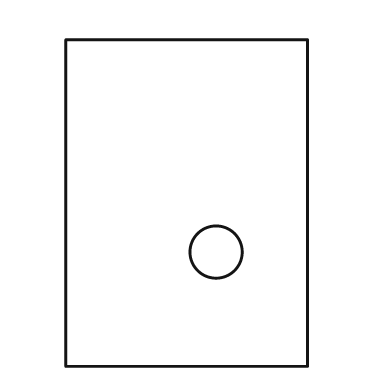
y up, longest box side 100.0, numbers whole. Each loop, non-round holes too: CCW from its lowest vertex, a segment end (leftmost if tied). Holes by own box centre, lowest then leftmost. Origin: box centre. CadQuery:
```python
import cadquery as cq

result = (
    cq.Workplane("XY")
    .moveTo(-37.0, -50.0)
    .lineTo(37.0, -50.0)
    .lineTo(37.0, 50.0)
    .lineTo(-37.0, 50.0)
    .close()
    .moveTo(9.0, -15.0)
    .circle(8.0)
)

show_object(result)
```